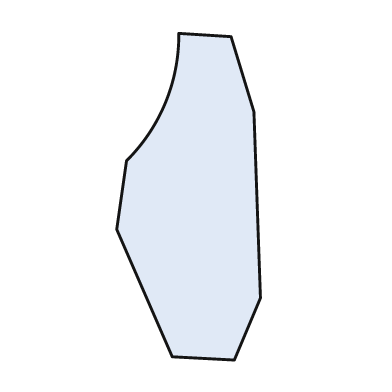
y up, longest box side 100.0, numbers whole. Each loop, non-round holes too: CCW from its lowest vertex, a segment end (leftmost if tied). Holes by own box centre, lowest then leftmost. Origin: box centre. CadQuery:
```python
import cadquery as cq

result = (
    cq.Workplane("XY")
    .moveTo(14.0, -50.0)
    .lineTo(22.0, -31.0)
    .lineTo(20.0, 26.0)
    .lineTo(13.0, 49.0)
    .lineTo(-3.0, 50.0)
    .threePointArc((-7.0, 29.0), (-19.0, 11.0))
    .lineTo(-22.0, -10.0)
    .lineTo(-5.0, -49.0)
    .close()
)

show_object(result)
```